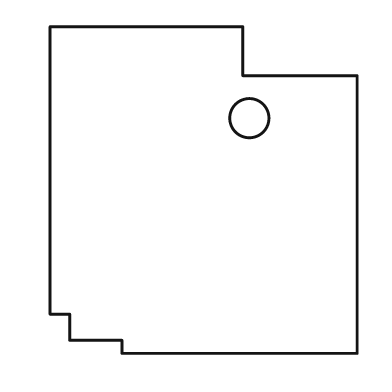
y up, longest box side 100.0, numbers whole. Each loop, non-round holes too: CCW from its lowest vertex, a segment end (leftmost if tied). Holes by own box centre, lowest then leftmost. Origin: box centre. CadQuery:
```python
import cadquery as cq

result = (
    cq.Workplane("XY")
    .moveTo(-25.0, -50.0)
    .lineTo(47.0, -50.0)
    .lineTo(47.0, 35.0)
    .lineTo(12.0, 35.0)
    .lineTo(12.0, 50.0)
    .lineTo(-47.0, 50.0)
    .lineTo(-47.0, -38.0)
    .lineTo(-41.0, -38.0)
    .lineTo(-41.0, -46.0)
    .lineTo(-25.0, -46.0)
    .close()
    .moveTo(14.0, 22.0)
    .circle(6.0)
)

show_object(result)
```